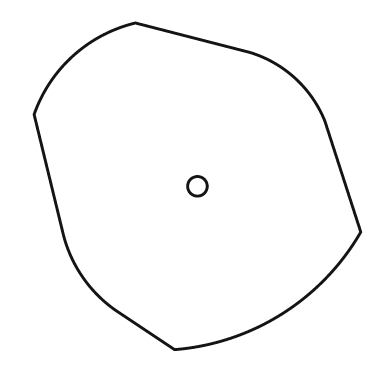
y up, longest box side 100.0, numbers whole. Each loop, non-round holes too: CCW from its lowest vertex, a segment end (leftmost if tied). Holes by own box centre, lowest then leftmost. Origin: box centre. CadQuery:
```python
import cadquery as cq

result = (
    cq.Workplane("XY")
    .moveTo(-7.0, -50.0)
    .threePointArc((26.0, -39.0), (50.0, -14.0))
    .lineTo(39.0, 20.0)
    .threePointArc((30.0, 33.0), (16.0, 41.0))
    .lineTo(-19.0, 50.0)
    .threePointArc((-38.0, 40.0), (-50.0, 22.0))
    .lineTo(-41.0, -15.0)
    .threePointArc((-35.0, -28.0), (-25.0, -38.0))
    .close()
    .moveTo(0.0, 0.0)
    .circle(3.0)
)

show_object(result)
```